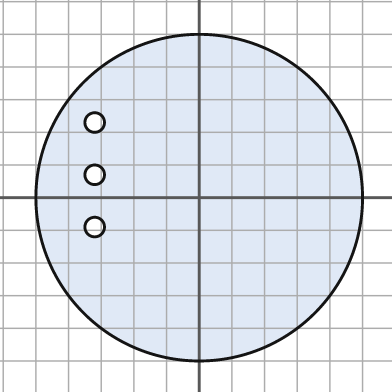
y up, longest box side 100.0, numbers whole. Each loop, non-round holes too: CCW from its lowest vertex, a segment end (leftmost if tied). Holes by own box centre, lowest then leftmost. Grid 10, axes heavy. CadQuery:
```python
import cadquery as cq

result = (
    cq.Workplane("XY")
    .moveTo(0.0, 0.0)
    .circle(50.0)
    .moveTo(-32.0, -9.0)
    .circle(3.0)
    .moveTo(-32.0, 7.0)
    .circle(3.0)
    .moveTo(-32.0, 23.0)
    .circle(3.0)
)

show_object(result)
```